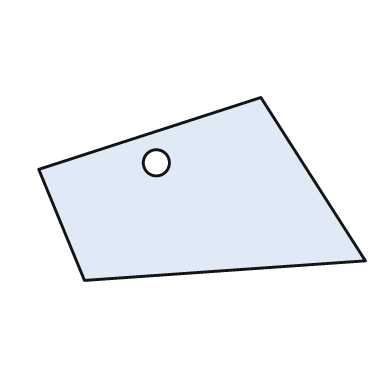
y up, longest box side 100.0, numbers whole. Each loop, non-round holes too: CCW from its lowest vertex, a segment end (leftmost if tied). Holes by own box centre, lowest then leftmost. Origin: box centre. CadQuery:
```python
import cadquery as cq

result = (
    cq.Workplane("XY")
    .moveTo(-36.0, -28.0)
    .lineTo(50.0, -22.0)
    .lineTo(18.0, 28.0)
    .lineTo(-50.0, 6.0)
    .close()
    .moveTo(-14.0, 8.0)
    .circle(4.0)
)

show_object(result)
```